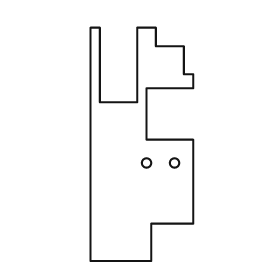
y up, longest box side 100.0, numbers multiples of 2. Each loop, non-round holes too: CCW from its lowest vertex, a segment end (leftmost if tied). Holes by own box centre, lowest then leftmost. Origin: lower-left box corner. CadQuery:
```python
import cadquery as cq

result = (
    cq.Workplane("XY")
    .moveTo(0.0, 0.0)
    .lineTo(26.0, 0.0)
    .lineTo(26.0, 16.0)
    .lineTo(44.0, 16.0)
    .lineTo(44.0, 52.0)
    .lineTo(24.0, 52.0)
    .lineTo(24.0, 74.0)
    .lineTo(44.0, 74.0)
    .lineTo(44.0, 80.0)
    .lineTo(40.0, 80.0)
    .lineTo(40.0, 92.0)
    .lineTo(28.0, 92.0)
    .lineTo(28.0, 100.0)
    .lineTo(20.0, 100.0)
    .lineTo(20.0, 68.0)
    .lineTo(4.0, 68.0)
    .lineTo(4.0, 100.0)
    .lineTo(0.0, 100.0)
    .close()
    .moveTo(24.0, 42.0)
    .circle(2.0)
    .moveTo(36.0, 42.0)
    .circle(2.0)
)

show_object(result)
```